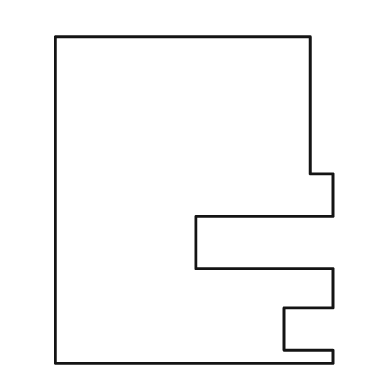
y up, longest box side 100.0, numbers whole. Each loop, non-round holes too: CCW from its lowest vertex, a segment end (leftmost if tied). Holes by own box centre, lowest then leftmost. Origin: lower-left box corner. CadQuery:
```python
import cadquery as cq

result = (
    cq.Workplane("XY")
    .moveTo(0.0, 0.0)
    .lineTo(85.0, 0.0)
    .lineTo(85.0, 4.0)
    .lineTo(70.0, 4.0)
    .lineTo(70.0, 17.0)
    .lineTo(85.0, 17.0)
    .lineTo(85.0, 29.0)
    .lineTo(43.0, 29.0)
    .lineTo(43.0, 45.0)
    .lineTo(85.0, 45.0)
    .lineTo(85.0, 58.0)
    .lineTo(78.0, 58.0)
    .lineTo(78.0, 100.0)
    .lineTo(0.0, 100.0)
    .close()
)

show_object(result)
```